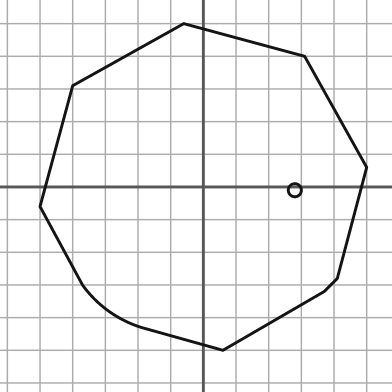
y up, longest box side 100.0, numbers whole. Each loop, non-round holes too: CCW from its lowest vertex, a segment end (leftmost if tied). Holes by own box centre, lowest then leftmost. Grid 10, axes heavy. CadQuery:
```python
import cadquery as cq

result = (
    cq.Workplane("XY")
    .moveTo(6.0, -50.0)
    .lineTo(37.0, -32.0)
    .lineTo(41.0, -28.0)
    .lineTo(50.0, 6.0)
    .lineTo(31.0, 40.0)
    .lineTo(-6.0, 50.0)
    .lineTo(-40.0, 31.0)
    .lineTo(-50.0, -6.0)
    .lineTo(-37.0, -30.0)
    .threePointArc((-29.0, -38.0), (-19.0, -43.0))
    .close()
    .moveTo(28.0, -1.0)
    .circle(2.0)
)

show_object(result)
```